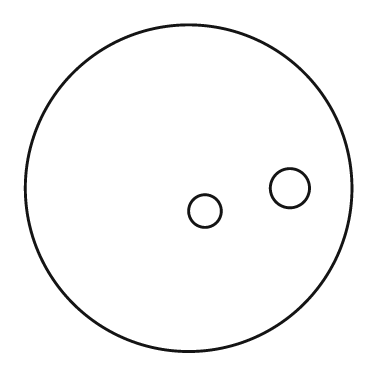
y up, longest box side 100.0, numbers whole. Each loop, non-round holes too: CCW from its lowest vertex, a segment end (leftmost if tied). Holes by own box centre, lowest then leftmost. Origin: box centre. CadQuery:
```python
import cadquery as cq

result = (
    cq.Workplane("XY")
    .moveTo(0.0, 0.0)
    .circle(50.0)
    .moveTo(5.0, -7.0)
    .circle(5.0)
    .moveTo(31.0, 0.0)
    .circle(6.0)
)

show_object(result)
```